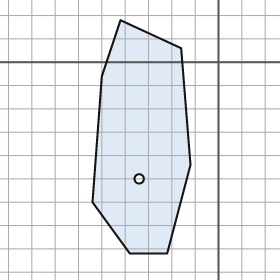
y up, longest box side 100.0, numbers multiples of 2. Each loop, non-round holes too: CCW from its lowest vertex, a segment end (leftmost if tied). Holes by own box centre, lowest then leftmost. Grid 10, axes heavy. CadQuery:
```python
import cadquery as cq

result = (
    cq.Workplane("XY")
    .moveTo(-38.0, -82.0)
    .lineTo(-22.0, -82.0)
    .lineTo(-12.0, -44.0)
    .lineTo(-16.0, 6.0)
    .lineTo(-42.0, 18.0)
    .lineTo(-50.0, -6.0)
    .lineTo(-54.0, -60.0)
    .close()
    .moveTo(-34.0, -50.0)
    .circle(2.0)
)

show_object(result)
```